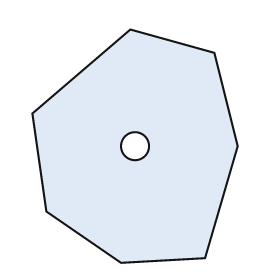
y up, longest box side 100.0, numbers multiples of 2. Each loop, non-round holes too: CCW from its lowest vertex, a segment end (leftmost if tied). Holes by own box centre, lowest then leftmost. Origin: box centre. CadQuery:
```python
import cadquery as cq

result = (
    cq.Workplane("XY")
    .moveTo(-6.0, -50.0)
    .lineTo(30.0, -48.0)
    .lineTo(44.0, 0.0)
    .lineTo(34.0, 40.0)
    .lineTo(-2.0, 50.0)
    .lineTo(-44.0, 14.0)
    .lineTo(-38.0, -28.0)
    .close()
    .moveTo(0.0, 0.0)
    .circle(6.0)
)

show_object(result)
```